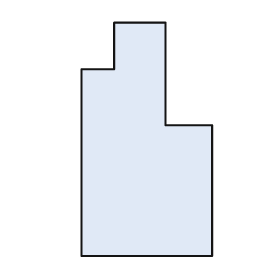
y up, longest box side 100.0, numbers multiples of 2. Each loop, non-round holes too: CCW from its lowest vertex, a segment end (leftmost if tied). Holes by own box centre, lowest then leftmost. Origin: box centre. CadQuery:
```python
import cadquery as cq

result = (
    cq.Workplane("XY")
    .moveTo(-28.0, -50.0)
    .lineTo(28.0, -50.0)
    .lineTo(28.0, 6.0)
    .lineTo(8.0, 6.0)
    .lineTo(8.0, 50.0)
    .lineTo(-14.0, 50.0)
    .lineTo(-14.0, 30.0)
    .lineTo(-28.0, 30.0)
    .close()
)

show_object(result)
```